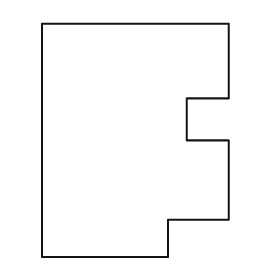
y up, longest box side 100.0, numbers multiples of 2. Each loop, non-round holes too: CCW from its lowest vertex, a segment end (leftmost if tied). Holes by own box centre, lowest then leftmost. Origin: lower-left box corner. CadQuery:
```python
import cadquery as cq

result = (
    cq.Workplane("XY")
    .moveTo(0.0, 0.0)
    .lineTo(54.0, 0.0)
    .lineTo(54.0, 16.0)
    .lineTo(80.0, 16.0)
    .lineTo(80.0, 50.0)
    .lineTo(62.0, 50.0)
    .lineTo(62.0, 68.0)
    .lineTo(80.0, 68.0)
    .lineTo(80.0, 100.0)
    .lineTo(0.0, 100.0)
    .close()
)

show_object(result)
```